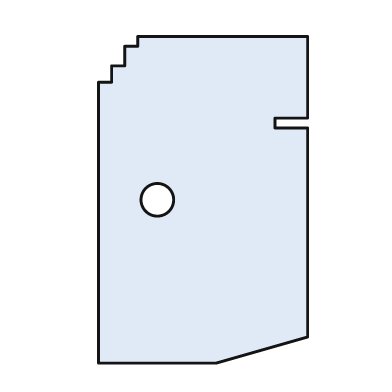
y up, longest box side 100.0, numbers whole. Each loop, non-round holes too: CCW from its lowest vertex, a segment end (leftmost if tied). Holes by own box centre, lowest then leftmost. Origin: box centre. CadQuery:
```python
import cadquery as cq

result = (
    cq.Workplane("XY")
    .moveTo(-32.0, -50.0)
    .lineTo(4.0, -50.0)
    .lineTo(32.0, -42.0)
    .lineTo(32.0, 22.0)
    .lineTo(22.0, 22.0)
    .lineTo(22.0, 25.0)
    .lineTo(32.0, 25.0)
    .lineTo(32.0, 50.0)
    .lineTo(-20.0, 50.0)
    .lineTo(-20.0, 47.0)
    .lineTo(-24.0, 47.0)
    .lineTo(-24.0, 41.0)
    .lineTo(-28.0, 41.0)
    .lineTo(-28.0, 36.0)
    .lineTo(-32.0, 36.0)
    .close()
    .moveTo(-14.0, 0.0)
    .circle(5.0)
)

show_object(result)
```